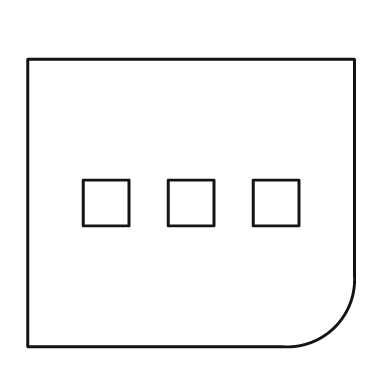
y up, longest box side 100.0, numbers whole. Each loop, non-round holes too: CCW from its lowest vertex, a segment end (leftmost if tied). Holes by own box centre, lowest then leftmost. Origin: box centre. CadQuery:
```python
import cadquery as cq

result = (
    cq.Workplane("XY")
    .moveTo(-50.0, -44.0)
    .lineTo(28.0, -44.0)
    .threePointArc((44.0, -38.0), (50.0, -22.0))
    .lineTo(50.0, 44.0)
    .lineTo(-50.0, 44.0)
    .close()
    .moveTo(-33.0, -7.0)
    .lineTo(-19.0, -7.0)
    .lineTo(-19.0, 7.0)
    .lineTo(-33.0, 7.0)
    .close()
    .moveTo(-7.0, -7.0)
    .lineTo(7.0, -7.0)
    .lineTo(7.0, 7.0)
    .lineTo(-7.0, 7.0)
    .close()
    .moveTo(19.0, -7.0)
    .lineTo(33.0, -7.0)
    .lineTo(33.0, 7.0)
    .lineTo(19.0, 7.0)
    .close()
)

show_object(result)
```